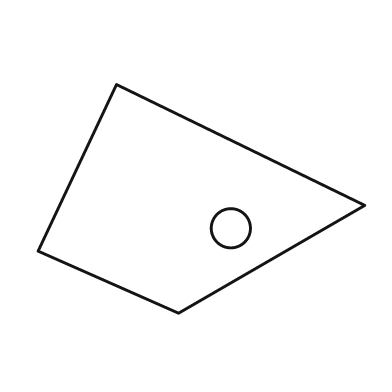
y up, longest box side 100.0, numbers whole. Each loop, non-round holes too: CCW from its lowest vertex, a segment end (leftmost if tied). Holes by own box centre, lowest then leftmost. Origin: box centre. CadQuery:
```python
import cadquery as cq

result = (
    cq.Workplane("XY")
    .moveTo(-7.0, -35.0)
    .lineTo(50.0, -2.0)
    .lineTo(-26.0, 35.0)
    .lineTo(-50.0, -16.0)
    .close()
    .moveTo(9.0, -9.0)
    .circle(6.0)
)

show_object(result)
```